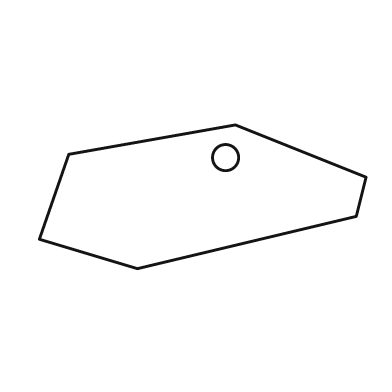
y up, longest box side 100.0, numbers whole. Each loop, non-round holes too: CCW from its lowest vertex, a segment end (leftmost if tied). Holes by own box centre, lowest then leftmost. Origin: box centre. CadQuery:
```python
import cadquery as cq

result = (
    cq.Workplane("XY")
    .moveTo(-20.0, -22.0)
    .lineTo(47.0, -6.0)
    .lineTo(50.0, 6.0)
    .lineTo(10.0, 22.0)
    .lineTo(-41.0, 13.0)
    .lineTo(-50.0, -13.0)
    .close()
    .moveTo(7.0, 12.0)
    .circle(4.0)
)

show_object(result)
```